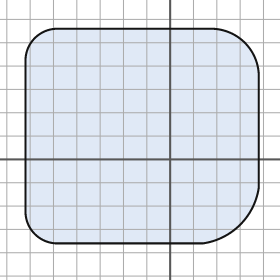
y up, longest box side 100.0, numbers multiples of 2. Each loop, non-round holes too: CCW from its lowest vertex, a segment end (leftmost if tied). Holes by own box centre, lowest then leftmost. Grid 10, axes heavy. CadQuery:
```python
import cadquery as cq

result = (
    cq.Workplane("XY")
    .moveTo(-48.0, -36.0)
    .lineTo(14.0, -36.0)
    .threePointArc((30.0, -28.0), (38.0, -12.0))
    .lineTo(38.0, 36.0)
    .threePointArc((32.0, 50.0), (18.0, 56.0))
    .lineTo(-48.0, 56.0)
    .threePointArc((-58.0, 52.0), (-62.0, 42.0))
    .lineTo(-62.0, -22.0)
    .threePointArc((-58.0, -32.0), (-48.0, -36.0))
    .close()
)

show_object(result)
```